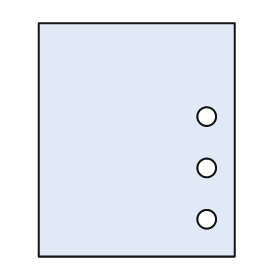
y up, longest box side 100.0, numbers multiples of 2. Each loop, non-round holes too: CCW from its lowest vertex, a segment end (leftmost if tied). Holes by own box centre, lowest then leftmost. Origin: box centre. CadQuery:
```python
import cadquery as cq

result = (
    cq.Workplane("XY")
    .moveTo(-42.0, -50.0)
    .lineTo(42.0, -50.0)
    .lineTo(42.0, 50.0)
    .lineTo(-42.0, 50.0)
    .close()
    .moveTo(30.0, -34.0)
    .circle(4.0)
    .moveTo(30.0, -12.0)
    .circle(4.0)
    .moveTo(30.0, 10.0)
    .circle(4.0)
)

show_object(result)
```